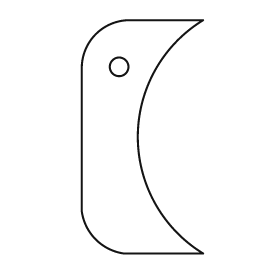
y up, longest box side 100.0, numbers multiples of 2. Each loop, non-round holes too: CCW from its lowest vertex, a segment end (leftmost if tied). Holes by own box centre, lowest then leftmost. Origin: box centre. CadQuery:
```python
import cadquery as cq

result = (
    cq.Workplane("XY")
    .moveTo(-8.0, -50.0)
    .lineTo(26.0, -50.0)
    .threePointArc((-2.0, 0.0), (26.0, 50.0))
    .lineTo(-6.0, 50.0)
    .threePointArc((-20.0, 44.0), (-26.0, 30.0))
    .lineTo(-26.0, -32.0)
    .threePointArc((-20.0, -44.0), (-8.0, -50.0))
    .close()
    .moveTo(-10.0, 30.0)
    .circle(4.0)
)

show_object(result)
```